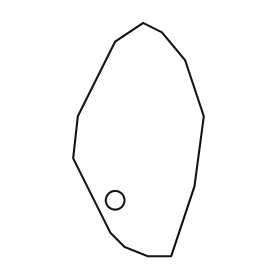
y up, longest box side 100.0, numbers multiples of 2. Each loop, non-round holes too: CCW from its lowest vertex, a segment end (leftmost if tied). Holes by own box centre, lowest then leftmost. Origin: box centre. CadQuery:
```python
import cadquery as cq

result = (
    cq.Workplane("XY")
    .moveTo(4.0, -50.0)
    .lineTo(14.0, -50.0)
    .lineTo(24.0, -20.0)
    .lineTo(28.0, 10.0)
    .lineTo(20.0, 34.0)
    .lineTo(10.0, 46.0)
    .lineTo(2.0, 50.0)
    .lineTo(-10.0, 42.0)
    .lineTo(-26.0, 10.0)
    .lineTo(-28.0, -8.0)
    .lineTo(-12.0, -40.0)
    .lineTo(-6.0, -46.0)
    .close()
    .moveTo(-10.0, -26.0)
    .circle(4.0)
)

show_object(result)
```